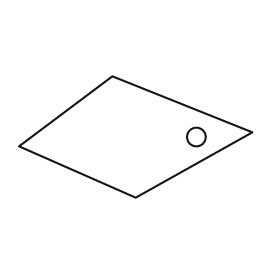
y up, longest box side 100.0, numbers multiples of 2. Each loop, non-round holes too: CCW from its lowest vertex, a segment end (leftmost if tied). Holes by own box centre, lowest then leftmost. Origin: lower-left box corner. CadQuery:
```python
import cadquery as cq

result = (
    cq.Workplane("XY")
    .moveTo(50.0, 0.0)
    .lineTo(100.0, 28.0)
    .lineTo(40.0, 52.0)
    .lineTo(0.0, 22.0)
    .close()
    .moveTo(76.0, 26.0)
    .circle(4.0)
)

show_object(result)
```